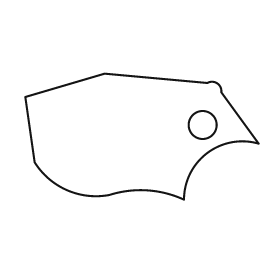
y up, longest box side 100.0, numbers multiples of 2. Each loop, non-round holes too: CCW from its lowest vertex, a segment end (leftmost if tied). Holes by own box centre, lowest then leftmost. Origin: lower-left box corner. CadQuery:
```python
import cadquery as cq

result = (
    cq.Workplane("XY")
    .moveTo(68.0, 0.0)
    .threePointArc((78.0, 20.0), (100.0, 24.0))
    .lineTo(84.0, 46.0)
    .threePointArc((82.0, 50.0), (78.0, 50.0))
    .lineTo(34.0, 54.0)
    .lineTo(0.0, 44.0)
    .lineTo(4.0, 16.0)
    .threePointArc((18.0, 4.0), (36.0, 2.0))
    .threePointArc((52.0, 4.0), (68.0, 0.0))
    .close()
    .moveTo(76.0, 32.0)
    .circle(6.0)
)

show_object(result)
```